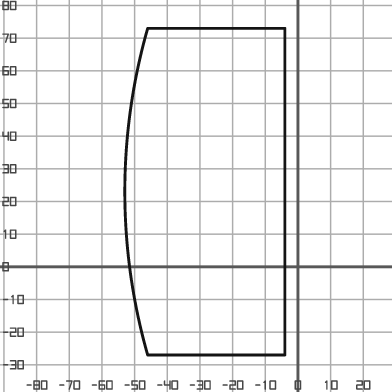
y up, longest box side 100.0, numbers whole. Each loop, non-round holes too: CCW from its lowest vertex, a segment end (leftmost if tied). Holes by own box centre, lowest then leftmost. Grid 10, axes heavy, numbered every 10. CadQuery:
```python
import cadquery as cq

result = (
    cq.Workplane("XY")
    .moveTo(-46.0, -27.0)
    .lineTo(-4.0, -27.0)
    .lineTo(-4.0, 73.0)
    .lineTo(-46.0, 73.0)
    .threePointArc((-53.0, 23.0), (-46.0, -27.0))
    .close()
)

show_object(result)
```